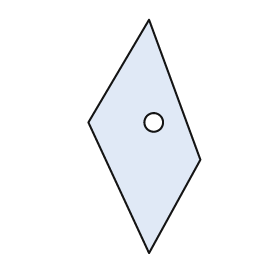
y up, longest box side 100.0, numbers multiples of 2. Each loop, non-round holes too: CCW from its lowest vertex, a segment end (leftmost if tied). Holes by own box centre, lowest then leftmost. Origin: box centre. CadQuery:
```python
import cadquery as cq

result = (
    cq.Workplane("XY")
    .moveTo(2.0, -50.0)
    .lineTo(24.0, -10.0)
    .lineTo(2.0, 50.0)
    .lineTo(-24.0, 6.0)
    .close()
    .moveTo(4.0, 6.0)
    .circle(4.0)
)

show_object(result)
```